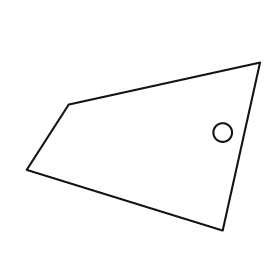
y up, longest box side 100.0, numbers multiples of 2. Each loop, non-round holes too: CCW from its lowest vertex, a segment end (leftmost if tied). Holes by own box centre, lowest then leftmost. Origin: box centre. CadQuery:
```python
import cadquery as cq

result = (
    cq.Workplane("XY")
    .moveTo(34.0, -36.0)
    .lineTo(50.0, 36.0)
    .lineTo(-32.0, 18.0)
    .lineTo(-50.0, -10.0)
    .close()
    .moveTo(34.0, 6.0)
    .circle(4.0)
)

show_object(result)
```